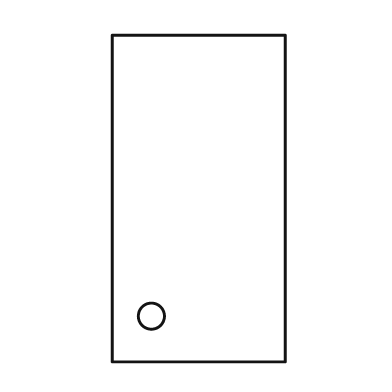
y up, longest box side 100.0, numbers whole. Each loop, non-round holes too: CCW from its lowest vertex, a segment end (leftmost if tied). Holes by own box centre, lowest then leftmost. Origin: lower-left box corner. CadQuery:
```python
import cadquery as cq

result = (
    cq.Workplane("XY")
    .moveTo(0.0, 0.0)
    .lineTo(53.0, 0.0)
    .lineTo(53.0, 100.0)
    .lineTo(0.0, 100.0)
    .close()
    .moveTo(12.0, 14.0)
    .circle(4.0)
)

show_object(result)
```